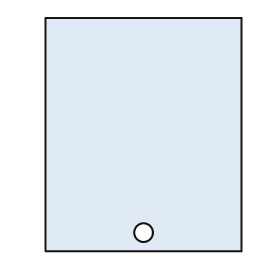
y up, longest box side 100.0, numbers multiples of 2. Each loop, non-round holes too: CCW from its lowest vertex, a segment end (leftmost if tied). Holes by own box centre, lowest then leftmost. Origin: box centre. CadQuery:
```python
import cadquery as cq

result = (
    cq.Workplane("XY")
    .moveTo(-42.0, -50.0)
    .lineTo(42.0, -50.0)
    .lineTo(42.0, 50.0)
    .lineTo(-42.0, 50.0)
    .close()
    .moveTo(0.0, -42.0)
    .circle(4.0)
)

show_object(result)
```